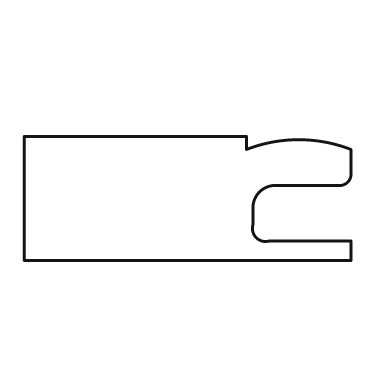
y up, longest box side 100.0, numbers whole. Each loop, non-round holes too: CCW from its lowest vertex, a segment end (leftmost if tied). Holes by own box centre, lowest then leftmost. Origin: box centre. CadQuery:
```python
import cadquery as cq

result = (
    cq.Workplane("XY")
    .moveTo(-50.0, -19.0)
    .lineTo(50.0, -19.0)
    .lineTo(50.0, -13.0)
    .lineTo(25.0, -13.0)
    .threePointArc((21.0, -12.0), (20.0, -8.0))
    .lineTo(20.0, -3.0)
    .threePointArc((22.0, 2.0), (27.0, 4.0))
    .lineTo(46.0, 4.0)
    .threePointArc((49.0, 5.0), (50.0, 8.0))
    .lineTo(50.0, 15.0)
    .threePointArc((34.0, 18.0), (18.0, 15.0))
    .lineTo(18.0, 19.0)
    .lineTo(-50.0, 19.0)
    .close()
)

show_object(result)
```